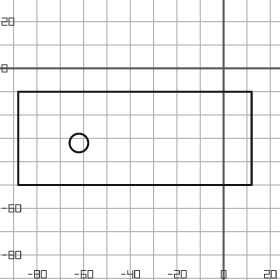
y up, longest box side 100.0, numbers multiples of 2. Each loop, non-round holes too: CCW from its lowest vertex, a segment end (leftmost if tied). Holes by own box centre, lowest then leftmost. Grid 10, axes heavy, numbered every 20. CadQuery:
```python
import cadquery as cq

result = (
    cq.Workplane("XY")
    .moveTo(-88.0, -50.0)
    .lineTo(12.0, -50.0)
    .lineTo(12.0, -10.0)
    .lineTo(-88.0, -10.0)
    .close()
    .moveTo(-62.0, -32.0)
    .circle(4.0)
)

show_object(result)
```